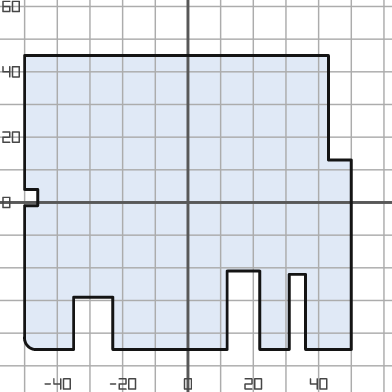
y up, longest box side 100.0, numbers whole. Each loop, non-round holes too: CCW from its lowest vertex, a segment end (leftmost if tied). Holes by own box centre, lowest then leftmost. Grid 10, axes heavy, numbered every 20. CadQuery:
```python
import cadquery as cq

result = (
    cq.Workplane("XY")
    .moveTo(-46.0, -45.0)
    .lineTo(-35.0, -45.0)
    .lineTo(-35.0, -29.0)
    .lineTo(-23.0, -29.0)
    .lineTo(-23.0, -45.0)
    .lineTo(12.0, -45.0)
    .lineTo(12.0, -21.0)
    .lineTo(22.0, -21.0)
    .lineTo(22.0, -45.0)
    .lineTo(31.0, -45.0)
    .lineTo(31.0, -22.0)
    .lineTo(36.0, -22.0)
    .lineTo(36.0, -45.0)
    .lineTo(50.0, -45.0)
    .lineTo(50.0, 13.0)
    .lineTo(43.0, 13.0)
    .lineTo(43.0, 45.0)
    .lineTo(-50.0, 45.0)
    .lineTo(-50.0, 4.0)
    .lineTo(-46.0, 4.0)
    .lineTo(-46.0, -1.0)
    .lineTo(-50.0, -1.0)
    .lineTo(-50.0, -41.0)
    .threePointArc((-49.0, -44.0), (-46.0, -45.0))
    .close()
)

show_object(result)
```